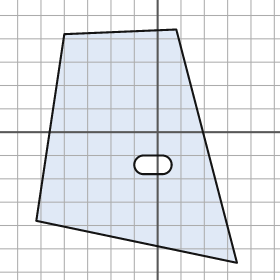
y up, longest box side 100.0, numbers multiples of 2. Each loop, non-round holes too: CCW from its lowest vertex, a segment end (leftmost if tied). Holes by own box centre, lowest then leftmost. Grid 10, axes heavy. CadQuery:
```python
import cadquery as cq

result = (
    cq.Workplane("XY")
    .moveTo(34.0, -56.0)
    .lineTo(8.0, 44.0)
    .lineTo(-40.0, 42.0)
    .lineTo(-52.0, -38.0)
    .close()
    .moveTo(-6.0, -18.0)
    .lineTo(2.0, -18.0)
    .threePointArc((6.0, -14.0), (2.0, -10.0))
    .lineTo(-6.0, -10.0)
    .threePointArc((-10.0, -14.0), (-6.0, -18.0))
    .close()
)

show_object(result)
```